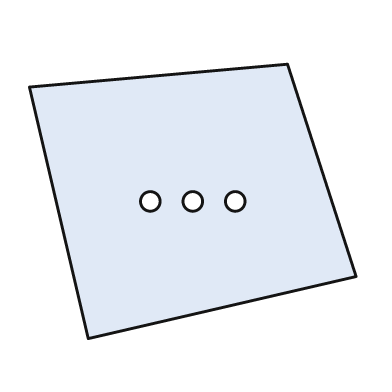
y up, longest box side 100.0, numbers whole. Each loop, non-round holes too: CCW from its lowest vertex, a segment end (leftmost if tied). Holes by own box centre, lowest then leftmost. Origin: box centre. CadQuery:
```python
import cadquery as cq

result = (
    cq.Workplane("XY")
    .moveTo(-32.0, -42.0)
    .lineTo(50.0, -23.0)
    .lineTo(29.0, 42.0)
    .lineTo(-50.0, 35.0)
    .close()
    .moveTo(-13.0, 0.0)
    .circle(3.0)
    .moveTo(0.0, 0.0)
    .circle(3.0)
    .moveTo(13.0, 0.0)
    .circle(3.0)
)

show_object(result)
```